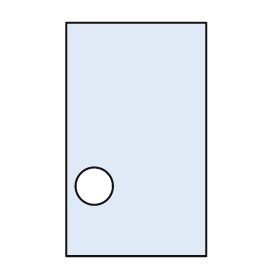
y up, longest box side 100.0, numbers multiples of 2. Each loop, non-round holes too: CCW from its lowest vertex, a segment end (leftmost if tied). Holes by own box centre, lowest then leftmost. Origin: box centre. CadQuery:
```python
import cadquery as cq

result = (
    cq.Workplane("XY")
    .moveTo(-30.0, -50.0)
    .lineTo(30.0, -50.0)
    .lineTo(30.0, 50.0)
    .lineTo(-30.0, 50.0)
    .close()
    .moveTo(-18.0, -20.0)
    .circle(8.0)
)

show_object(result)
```